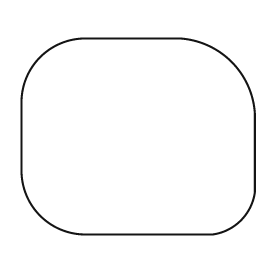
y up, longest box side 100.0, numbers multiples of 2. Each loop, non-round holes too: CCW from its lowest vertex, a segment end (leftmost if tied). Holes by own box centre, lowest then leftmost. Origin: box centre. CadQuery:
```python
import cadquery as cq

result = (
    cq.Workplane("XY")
    .moveTo(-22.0, -42.0)
    .lineTo(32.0, -42.0)
    .threePointArc((44.0, -36.0), (50.0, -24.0))
    .lineTo(50.0, 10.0)
    .threePointArc((40.0, 32.0), (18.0, 42.0))
    .lineTo(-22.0, 42.0)
    .threePointArc((-42.0, 34.0), (-50.0, 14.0))
    .lineTo(-50.0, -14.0)
    .threePointArc((-42.0, -34.0), (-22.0, -42.0))
    .close()
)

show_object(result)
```